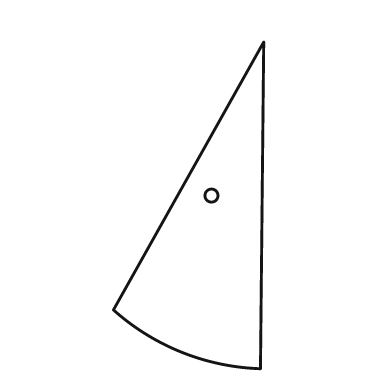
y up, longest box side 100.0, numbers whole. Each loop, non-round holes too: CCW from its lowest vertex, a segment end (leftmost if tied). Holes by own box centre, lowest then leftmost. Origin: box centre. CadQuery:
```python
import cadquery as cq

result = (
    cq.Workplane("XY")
    .moveTo(22.0, -50.0)
    .lineTo(23.0, 50.0)
    .lineTo(-23.0, -32.0)
    .threePointArc((-2.0, -45.0), (22.0, -50.0))
    .close()
    .moveTo(7.0, 3.0)
    .circle(2.0)
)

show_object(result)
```